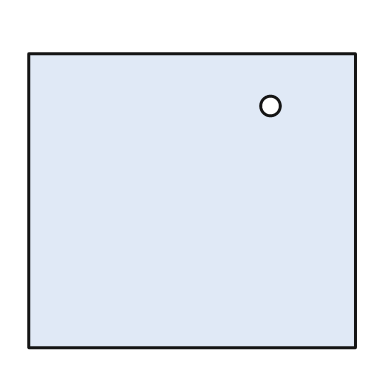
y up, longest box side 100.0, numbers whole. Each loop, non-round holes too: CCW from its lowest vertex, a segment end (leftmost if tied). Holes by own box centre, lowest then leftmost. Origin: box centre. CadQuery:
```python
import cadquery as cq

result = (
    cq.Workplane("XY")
    .moveTo(-50.0, -45.0)
    .lineTo(50.0, -45.0)
    .lineTo(50.0, 45.0)
    .lineTo(-50.0, 45.0)
    .close()
    .moveTo(24.0, 29.0)
    .circle(3.0)
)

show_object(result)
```